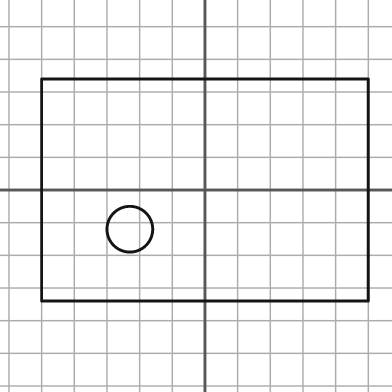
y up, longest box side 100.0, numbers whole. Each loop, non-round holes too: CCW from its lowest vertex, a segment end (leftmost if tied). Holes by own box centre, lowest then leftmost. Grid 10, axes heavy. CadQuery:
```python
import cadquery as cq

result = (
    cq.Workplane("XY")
    .moveTo(-50.0, -34.0)
    .lineTo(50.0, -34.0)
    .lineTo(50.0, 34.0)
    .lineTo(-50.0, 34.0)
    .close()
    .moveTo(-23.0, -12.0)
    .circle(7.0)
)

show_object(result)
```